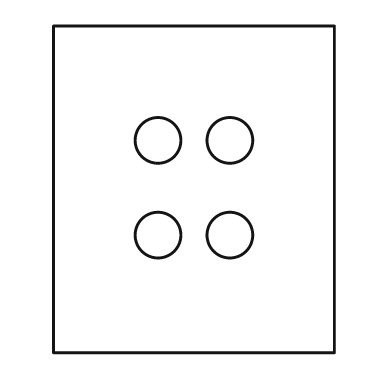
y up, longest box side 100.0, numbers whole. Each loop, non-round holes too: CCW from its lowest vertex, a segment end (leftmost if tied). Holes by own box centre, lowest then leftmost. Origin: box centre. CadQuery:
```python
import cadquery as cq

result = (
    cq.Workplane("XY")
    .moveTo(-43.0, -50.0)
    .lineTo(43.0, -50.0)
    .lineTo(43.0, 50.0)
    .lineTo(-43.0, 50.0)
    .close()
    .moveTo(-11.0, -14.0)
    .circle(7.0)
    .moveTo(11.0, -14.0)
    .circle(7.0)
    .moveTo(-11.0, 15.0)
    .circle(7.0)
    .moveTo(11.0, 15.0)
    .circle(7.0)
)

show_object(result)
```